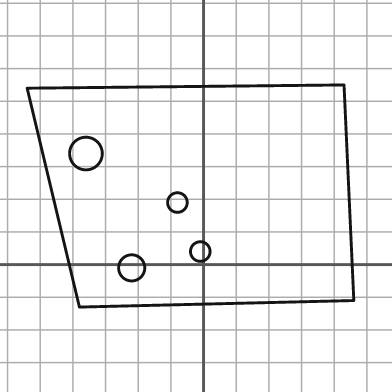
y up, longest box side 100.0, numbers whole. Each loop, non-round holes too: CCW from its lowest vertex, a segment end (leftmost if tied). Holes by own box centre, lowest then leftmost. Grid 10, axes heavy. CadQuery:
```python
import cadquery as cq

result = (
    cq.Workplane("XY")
    .moveTo(-38.0, -13.0)
    .lineTo(46.0, -11.0)
    .lineTo(43.0, 55.0)
    .lineTo(-54.0, 54.0)
    .close()
    .moveTo(-22.0, -1.0)
    .circle(4.0)
    .moveTo(-1.0, 4.0)
    .circle(3.0)
    .moveTo(-8.0, 19.0)
    .circle(3.0)
    .moveTo(-36.0, 34.0)
    .circle(5.0)
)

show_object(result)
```